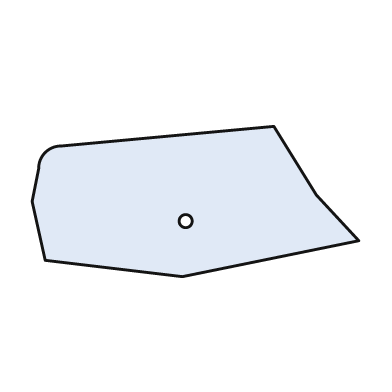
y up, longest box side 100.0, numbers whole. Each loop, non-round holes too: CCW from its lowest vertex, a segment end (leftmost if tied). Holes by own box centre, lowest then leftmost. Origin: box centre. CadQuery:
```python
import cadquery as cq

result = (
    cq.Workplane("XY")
    .moveTo(-4.0, -23.0)
    .lineTo(50.0, -12.0)
    .lineTo(37.0, 2.0)
    .lineTo(24.0, 23.0)
    .lineTo(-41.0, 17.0)
    .threePointArc((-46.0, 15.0), (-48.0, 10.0))
    .lineTo(-50.0, 0.0)
    .lineTo(-46.0, -18.0)
    .close()
    .moveTo(-3.0, -6.0)
    .circle(2.0)
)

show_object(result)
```